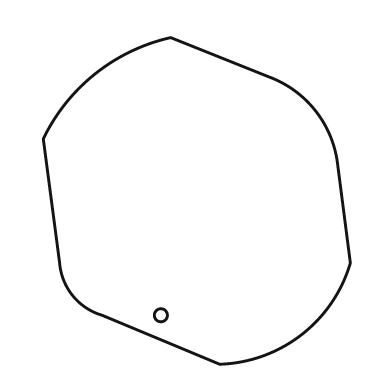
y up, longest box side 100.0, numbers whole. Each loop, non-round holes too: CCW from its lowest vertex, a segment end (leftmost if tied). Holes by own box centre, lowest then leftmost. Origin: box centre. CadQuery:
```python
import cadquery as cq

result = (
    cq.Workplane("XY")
    .moveTo(7.0, -50.0)
    .threePointArc((32.0, -41.0), (47.0, -19.0))
    .lineTo(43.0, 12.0)
    .threePointArc((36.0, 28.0), (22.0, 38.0))
    .lineTo(-8.0, 50.0)
    .threePointArc((-31.0, 39.0), (-47.0, 19.0))
    .lineTo(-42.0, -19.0)
    .threePointArc((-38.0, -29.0), (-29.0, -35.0))
    .close()
    .moveTo(-11.0, -35.0)
    .circle(2.0)
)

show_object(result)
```